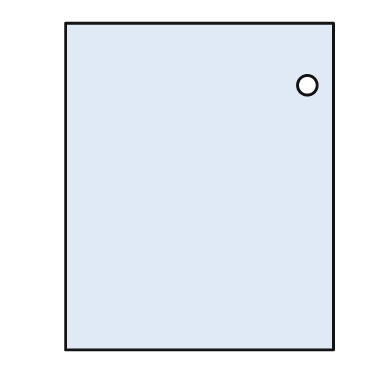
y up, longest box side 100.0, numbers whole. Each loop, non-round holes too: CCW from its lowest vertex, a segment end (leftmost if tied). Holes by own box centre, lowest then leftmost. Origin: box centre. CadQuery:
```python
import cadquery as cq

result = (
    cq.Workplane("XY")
    .moveTo(-41.0, -50.0)
    .lineTo(41.0, -50.0)
    .lineTo(41.0, 50.0)
    .lineTo(-41.0, 50.0)
    .close()
    .moveTo(33.0, 31.0)
    .circle(3.0)
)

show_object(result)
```